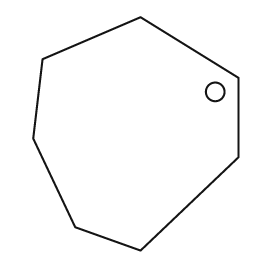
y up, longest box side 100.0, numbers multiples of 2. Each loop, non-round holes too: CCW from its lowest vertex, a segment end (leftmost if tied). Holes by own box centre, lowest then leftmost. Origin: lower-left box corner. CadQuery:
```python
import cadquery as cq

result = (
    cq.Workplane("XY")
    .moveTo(46.0, 0.0)
    .lineTo(88.0, 40.0)
    .lineTo(88.0, 74.0)
    .lineTo(46.0, 100.0)
    .lineTo(4.0, 82.0)
    .lineTo(0.0, 48.0)
    .lineTo(18.0, 10.0)
    .close()
    .moveTo(78.0, 68.0)
    .circle(4.0)
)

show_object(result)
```